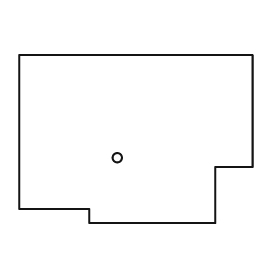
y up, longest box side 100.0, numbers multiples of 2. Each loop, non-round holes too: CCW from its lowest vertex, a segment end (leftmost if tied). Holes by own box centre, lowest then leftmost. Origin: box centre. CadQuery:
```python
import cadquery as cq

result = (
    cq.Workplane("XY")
    .moveTo(-20.0, -36.0)
    .lineTo(34.0, -36.0)
    .lineTo(34.0, -12.0)
    .lineTo(50.0, -12.0)
    .lineTo(50.0, 36.0)
    .lineTo(-50.0, 36.0)
    .lineTo(-50.0, -30.0)
    .lineTo(-20.0, -30.0)
    .close()
    .moveTo(-8.0, -8.0)
    .circle(2.0)
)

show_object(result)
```